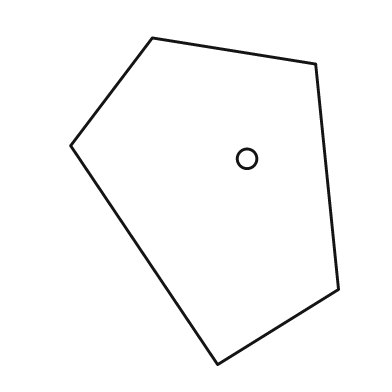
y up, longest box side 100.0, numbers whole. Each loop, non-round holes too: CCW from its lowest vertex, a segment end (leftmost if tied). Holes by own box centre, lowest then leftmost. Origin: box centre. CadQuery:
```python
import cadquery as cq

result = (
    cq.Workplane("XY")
    .moveTo(4.0, -50.0)
    .lineTo(41.0, -27.0)
    .lineTo(34.0, 42.0)
    .lineTo(-16.0, 50.0)
    .lineTo(-41.0, 17.0)
    .close()
    .moveTo(13.0, 13.0)
    .circle(3.0)
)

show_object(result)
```